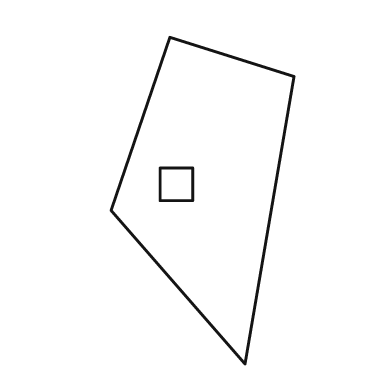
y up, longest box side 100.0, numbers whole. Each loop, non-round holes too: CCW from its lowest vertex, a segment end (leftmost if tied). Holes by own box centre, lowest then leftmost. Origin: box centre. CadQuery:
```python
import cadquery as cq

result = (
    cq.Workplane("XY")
    .moveTo(13.0, -50.0)
    .lineTo(28.0, 38.0)
    .lineTo(-10.0, 50.0)
    .lineTo(-28.0, -3.0)
    .close()
    .moveTo(-13.0, 0.0)
    .lineTo(-3.0, 0.0)
    .lineTo(-3.0, 10.0)
    .lineTo(-13.0, 10.0)
    .close()
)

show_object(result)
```